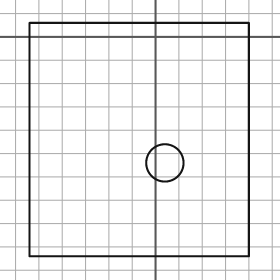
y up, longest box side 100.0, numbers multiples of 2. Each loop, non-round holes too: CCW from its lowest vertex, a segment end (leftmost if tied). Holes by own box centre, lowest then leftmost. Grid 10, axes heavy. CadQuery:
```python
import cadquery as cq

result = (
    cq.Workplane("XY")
    .moveTo(-54.0, -94.0)
    .lineTo(40.0, -94.0)
    .lineTo(40.0, 6.0)
    .lineTo(-54.0, 6.0)
    .close()
    .moveTo(4.0, -54.0)
    .circle(8.0)
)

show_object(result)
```